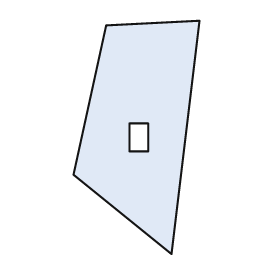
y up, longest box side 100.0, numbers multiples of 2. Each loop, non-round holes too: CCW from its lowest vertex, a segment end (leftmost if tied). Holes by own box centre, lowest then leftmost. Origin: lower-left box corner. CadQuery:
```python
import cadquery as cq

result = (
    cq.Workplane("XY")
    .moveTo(42.0, 0.0)
    .lineTo(54.0, 100.0)
    .lineTo(14.0, 98.0)
    .lineTo(0.0, 34.0)
    .close()
    .moveTo(24.0, 44.0)
    .lineTo(32.0, 44.0)
    .lineTo(32.0, 56.0)
    .lineTo(24.0, 56.0)
    .close()
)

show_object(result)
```